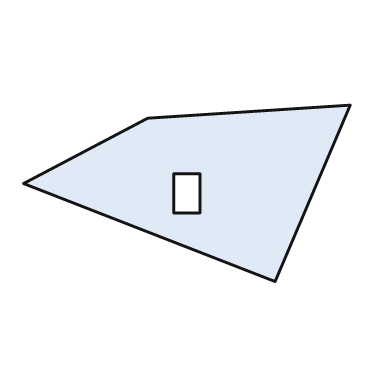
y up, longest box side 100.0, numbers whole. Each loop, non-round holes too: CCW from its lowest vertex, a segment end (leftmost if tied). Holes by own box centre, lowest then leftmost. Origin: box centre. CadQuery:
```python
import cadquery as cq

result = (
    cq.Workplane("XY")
    .moveTo(27.0, -27.0)
    .lineTo(50.0, 27.0)
    .lineTo(-12.0, 23.0)
    .lineTo(-50.0, 3.0)
    .close()
    .moveTo(-4.0, -6.0)
    .lineTo(4.0, -6.0)
    .lineTo(4.0, 6.0)
    .lineTo(-4.0, 6.0)
    .close()
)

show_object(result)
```